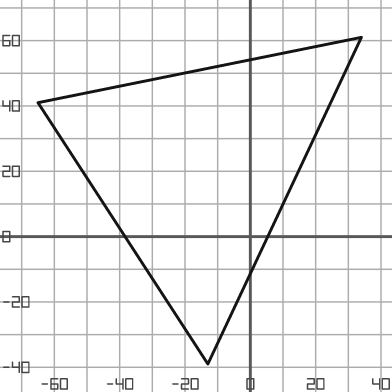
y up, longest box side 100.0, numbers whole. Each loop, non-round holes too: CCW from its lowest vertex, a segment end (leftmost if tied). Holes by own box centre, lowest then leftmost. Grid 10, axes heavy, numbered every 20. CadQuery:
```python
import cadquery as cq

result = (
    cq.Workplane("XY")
    .moveTo(-13.0, -39.0)
    .lineTo(34.0, 61.0)
    .lineTo(-65.0, 41.0)
    .close()
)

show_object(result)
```